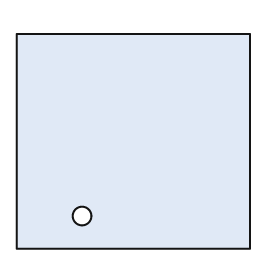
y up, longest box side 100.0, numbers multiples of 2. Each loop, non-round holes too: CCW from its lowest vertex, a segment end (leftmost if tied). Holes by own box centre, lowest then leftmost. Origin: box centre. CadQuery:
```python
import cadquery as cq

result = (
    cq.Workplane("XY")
    .moveTo(-50.0, -46.0)
    .lineTo(50.0, -46.0)
    .lineTo(50.0, 46.0)
    .lineTo(-50.0, 46.0)
    .close()
    .moveTo(-22.0, -32.0)
    .circle(4.0)
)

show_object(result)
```